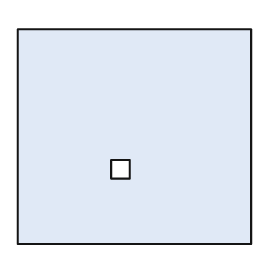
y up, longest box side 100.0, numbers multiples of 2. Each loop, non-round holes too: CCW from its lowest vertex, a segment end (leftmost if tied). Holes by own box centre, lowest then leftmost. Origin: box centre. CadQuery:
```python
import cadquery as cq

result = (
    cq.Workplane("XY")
    .moveTo(-50.0, -46.0)
    .lineTo(50.0, -46.0)
    .lineTo(50.0, 46.0)
    .lineTo(-50.0, 46.0)
    .close()
    .moveTo(-10.0, -18.0)
    .lineTo(-2.0, -18.0)
    .lineTo(-2.0, -10.0)
    .lineTo(-10.0, -10.0)
    .close()
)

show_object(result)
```